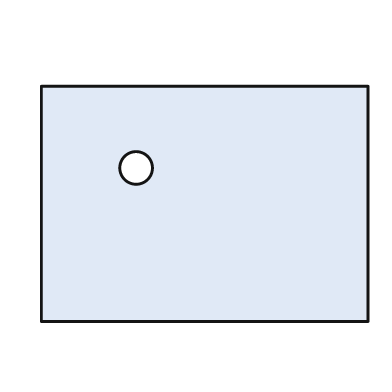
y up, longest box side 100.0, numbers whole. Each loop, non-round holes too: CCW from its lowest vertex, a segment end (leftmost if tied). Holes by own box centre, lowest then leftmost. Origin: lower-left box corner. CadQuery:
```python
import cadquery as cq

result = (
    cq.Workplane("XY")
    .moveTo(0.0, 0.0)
    .lineTo(100.0, 0.0)
    .lineTo(100.0, 72.0)
    .lineTo(0.0, 72.0)
    .close()
    .moveTo(29.0, 47.0)
    .circle(5.0)
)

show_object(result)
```